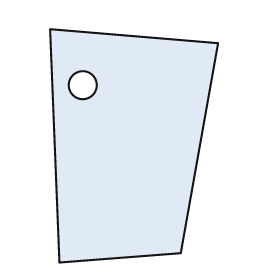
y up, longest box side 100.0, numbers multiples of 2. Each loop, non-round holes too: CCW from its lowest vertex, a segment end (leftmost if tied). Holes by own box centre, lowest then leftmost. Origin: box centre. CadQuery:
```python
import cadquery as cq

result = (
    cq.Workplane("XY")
    .moveTo(-32.0, -50.0)
    .lineTo(20.0, -46.0)
    .lineTo(36.0, 44.0)
    .lineTo(-36.0, 50.0)
    .close()
    .moveTo(-22.0, 26.0)
    .circle(6.0)
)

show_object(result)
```